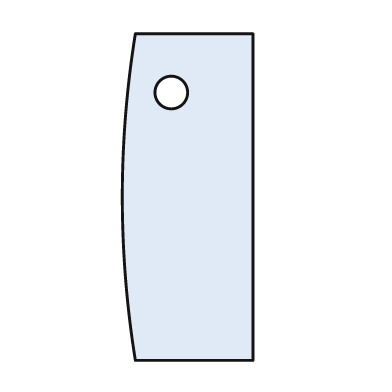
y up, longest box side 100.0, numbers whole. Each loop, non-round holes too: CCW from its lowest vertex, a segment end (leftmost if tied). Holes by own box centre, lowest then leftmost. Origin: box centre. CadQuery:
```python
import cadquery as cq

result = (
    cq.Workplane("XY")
    .moveTo(-16.0, -50.0)
    .lineTo(20.0, -50.0)
    .lineTo(20.0, 50.0)
    .lineTo(-16.0, 50.0)
    .threePointArc((-20.0, 0.0), (-16.0, -50.0))
    .close()
    .moveTo(-5.0, 32.0)
    .circle(5.0)
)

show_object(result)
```